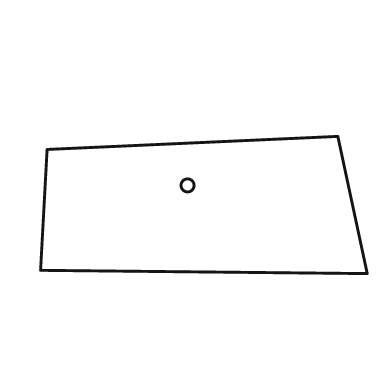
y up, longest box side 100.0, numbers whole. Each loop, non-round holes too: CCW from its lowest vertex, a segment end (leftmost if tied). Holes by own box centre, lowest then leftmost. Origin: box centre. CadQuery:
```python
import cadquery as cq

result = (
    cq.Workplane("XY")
    .moveTo(50.0, -21.0)
    .lineTo(41.0, 21.0)
    .lineTo(-48.0, 17.0)
    .lineTo(-50.0, -20.0)
    .close()
    .moveTo(-5.0, 6.0)
    .circle(2.0)
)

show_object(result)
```